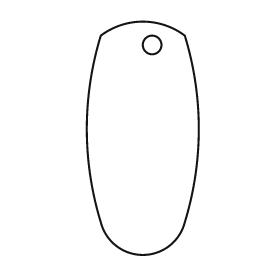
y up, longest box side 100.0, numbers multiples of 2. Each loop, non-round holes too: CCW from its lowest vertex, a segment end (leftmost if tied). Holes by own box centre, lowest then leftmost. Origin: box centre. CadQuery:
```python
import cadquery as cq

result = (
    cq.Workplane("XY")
    .moveTo(-18.0, -36.0)
    .threePointArc((0.0, -50.0), (18.0, -36.0))
    .threePointArc((24.0, 4.0), (18.0, 44.0))
    .threePointArc((0.0, 50.0), (-18.0, 44.0))
    .threePointArc((-24.0, 4.0), (-18.0, -36.0))
    .close()
    .moveTo(4.0, 40.0)
    .circle(4.0)
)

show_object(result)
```